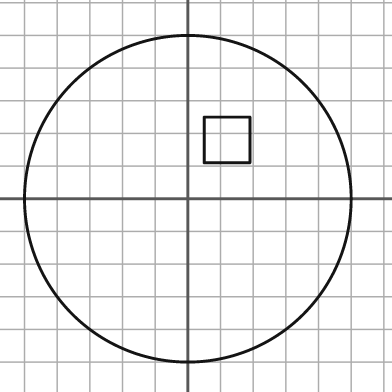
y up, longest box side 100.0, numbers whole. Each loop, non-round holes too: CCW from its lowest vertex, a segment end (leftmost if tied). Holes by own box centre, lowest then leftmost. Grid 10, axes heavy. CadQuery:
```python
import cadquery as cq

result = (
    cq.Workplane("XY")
    .moveTo(0.0, 0.0)
    .circle(50.0)
    .moveTo(5.0, 11.0)
    .lineTo(19.0, 11.0)
    .lineTo(19.0, 25.0)
    .lineTo(5.0, 25.0)
    .close()
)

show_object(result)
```